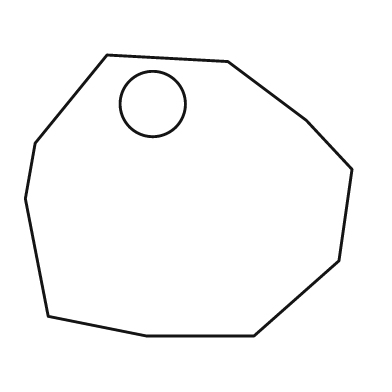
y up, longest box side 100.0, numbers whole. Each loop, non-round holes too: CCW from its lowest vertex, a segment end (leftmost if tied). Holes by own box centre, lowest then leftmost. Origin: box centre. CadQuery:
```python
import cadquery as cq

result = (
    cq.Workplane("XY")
    .moveTo(-13.0, -43.0)
    .lineTo(20.0, -43.0)
    .lineTo(46.0, -20.0)
    .lineTo(50.0, 8.0)
    .lineTo(36.0, 23.0)
    .lineTo(12.0, 41.0)
    .lineTo(-25.0, 43.0)
    .lineTo(-47.0, 16.0)
    .lineTo(-50.0, -1.0)
    .lineTo(-43.0, -37.0)
    .close()
    .moveTo(-11.0, 28.0)
    .circle(10.0)
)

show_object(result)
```